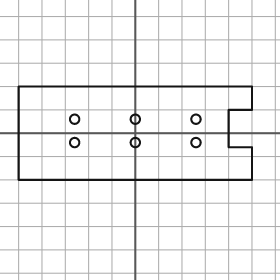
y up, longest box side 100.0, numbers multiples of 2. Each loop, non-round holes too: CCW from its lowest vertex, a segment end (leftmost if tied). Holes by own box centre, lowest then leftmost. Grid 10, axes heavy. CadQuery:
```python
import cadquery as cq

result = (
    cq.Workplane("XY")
    .moveTo(-50.0, -20.0)
    .lineTo(50.0, -20.0)
    .lineTo(50.0, -6.0)
    .lineTo(40.0, -6.0)
    .lineTo(40.0, 10.0)
    .lineTo(50.0, 10.0)
    .lineTo(50.0, 20.0)
    .lineTo(-50.0, 20.0)
    .close()
    .moveTo(-26.0, -4.0)
    .circle(2.0)
    .moveTo(0.0, -4.0)
    .circle(2.0)
    .moveTo(26.0, -4.0)
    .circle(2.0)
    .moveTo(-26.0, 6.0)
    .circle(2.0)
    .moveTo(0.0, 6.0)
    .circle(2.0)
    .moveTo(26.0, 6.0)
    .circle(2.0)
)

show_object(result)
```